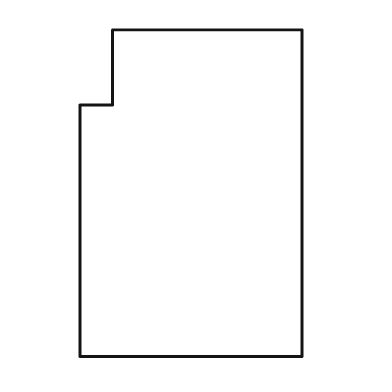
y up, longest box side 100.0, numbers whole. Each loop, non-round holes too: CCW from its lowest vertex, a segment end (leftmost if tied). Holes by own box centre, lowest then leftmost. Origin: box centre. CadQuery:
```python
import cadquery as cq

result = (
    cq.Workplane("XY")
    .moveTo(-34.0, -50.0)
    .lineTo(34.0, -50.0)
    .lineTo(34.0, 50.0)
    .lineTo(-24.0, 50.0)
    .lineTo(-24.0, 27.0)
    .lineTo(-34.0, 27.0)
    .close()
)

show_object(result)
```